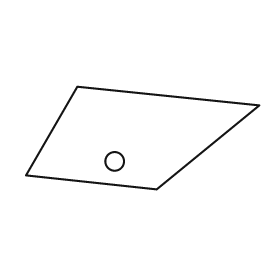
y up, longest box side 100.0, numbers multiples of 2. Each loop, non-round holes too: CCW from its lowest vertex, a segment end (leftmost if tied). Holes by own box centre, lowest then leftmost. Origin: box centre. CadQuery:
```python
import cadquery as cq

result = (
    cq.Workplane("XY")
    .moveTo(6.0, -22.0)
    .lineTo(50.0, 14.0)
    .lineTo(-28.0, 22.0)
    .lineTo(-50.0, -16.0)
    .close()
    .moveTo(-12.0, -10.0)
    .circle(4.0)
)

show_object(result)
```